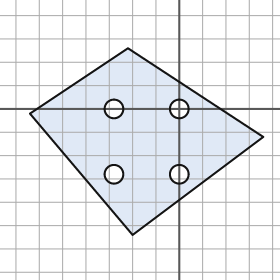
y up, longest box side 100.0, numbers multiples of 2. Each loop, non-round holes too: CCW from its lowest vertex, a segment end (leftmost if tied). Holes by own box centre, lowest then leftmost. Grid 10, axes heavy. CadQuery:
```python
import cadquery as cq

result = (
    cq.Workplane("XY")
    .moveTo(-20.0, -54.0)
    .lineTo(36.0, -12.0)
    .lineTo(-22.0, 26.0)
    .lineTo(-64.0, -2.0)
    .close()
    .moveTo(-28.0, -28.0)
    .circle(4.0)
    .moveTo(0.0, -28.0)
    .circle(4.0)
    .moveTo(-28.0, 0.0)
    .circle(4.0)
    .moveTo(0.0, 0.0)
    .circle(4.0)
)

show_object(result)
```